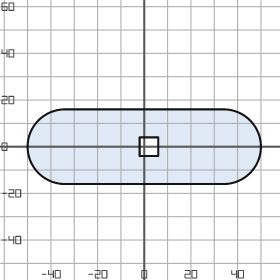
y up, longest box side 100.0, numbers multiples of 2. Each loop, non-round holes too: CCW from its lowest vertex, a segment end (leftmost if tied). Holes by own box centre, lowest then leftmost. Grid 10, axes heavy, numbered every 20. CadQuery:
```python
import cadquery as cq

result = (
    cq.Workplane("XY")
    .moveTo(-34.0, -16.0)
    .lineTo(34.0, -16.0)
    .threePointArc((50.0, 0.0), (34.0, 16.0))
    .lineTo(-34.0, 16.0)
    .threePointArc((-50.0, 0.0), (-34.0, -16.0))
    .close()
    .moveTo(-2.0, -4.0)
    .lineTo(6.0, -4.0)
    .lineTo(6.0, 4.0)
    .lineTo(-2.0, 4.0)
    .close()
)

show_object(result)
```